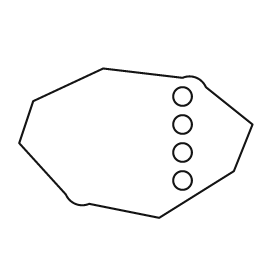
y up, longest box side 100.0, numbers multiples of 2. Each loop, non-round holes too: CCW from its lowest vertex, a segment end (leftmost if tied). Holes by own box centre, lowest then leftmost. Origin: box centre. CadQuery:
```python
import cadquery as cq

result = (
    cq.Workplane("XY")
    .moveTo(10.0, -32.0)
    .lineTo(42.0, -12.0)
    .lineTo(50.0, 8.0)
    .lineTo(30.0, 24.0)
    .threePointArc((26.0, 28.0), (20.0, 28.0))
    .lineTo(-14.0, 32.0)
    .lineTo(-44.0, 18.0)
    .lineTo(-50.0, 0.0)
    .lineTo(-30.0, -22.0)
    .threePointArc((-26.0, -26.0), (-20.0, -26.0))
    .close()
    .moveTo(20.0, -16.0)
    .circle(4.0)
    .moveTo(20.0, -4.0)
    .circle(4.0)
    .moveTo(20.0, 8.0)
    .circle(4.0)
    .moveTo(20.0, 20.0)
    .circle(4.0)
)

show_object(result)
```